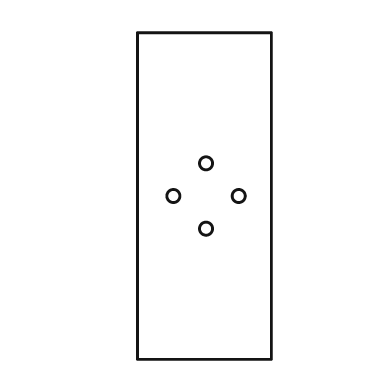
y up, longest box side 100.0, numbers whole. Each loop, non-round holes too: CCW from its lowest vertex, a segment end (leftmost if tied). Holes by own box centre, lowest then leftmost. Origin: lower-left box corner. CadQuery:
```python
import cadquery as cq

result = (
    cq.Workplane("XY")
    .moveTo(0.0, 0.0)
    .lineTo(41.0, 0.0)
    .lineTo(41.0, 100.0)
    .lineTo(0.0, 100.0)
    .close()
    .moveTo(21.0, 40.0)
    .circle(2.0)
    .moveTo(11.0, 50.0)
    .circle(2.0)
    .moveTo(31.0, 50.0)
    .circle(2.0)
    .moveTo(21.0, 60.0)
    .circle(2.0)
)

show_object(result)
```